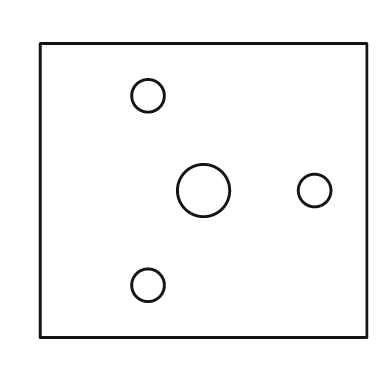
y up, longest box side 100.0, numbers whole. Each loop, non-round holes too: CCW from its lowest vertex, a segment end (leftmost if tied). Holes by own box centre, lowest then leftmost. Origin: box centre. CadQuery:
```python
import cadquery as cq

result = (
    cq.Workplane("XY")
    .moveTo(-50.0, -45.0)
    .lineTo(50.0, -45.0)
    .lineTo(50.0, 45.0)
    .lineTo(-50.0, 45.0)
    .close()
    .moveTo(-17.0, -29.0)
    .circle(5.0)
    .moveTo(0.0, 0.0)
    .circle(8.0)
    .moveTo(34.0, 0.0)
    .circle(5.0)
    .moveTo(-17.0, 29.0)
    .circle(5.0)
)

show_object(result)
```